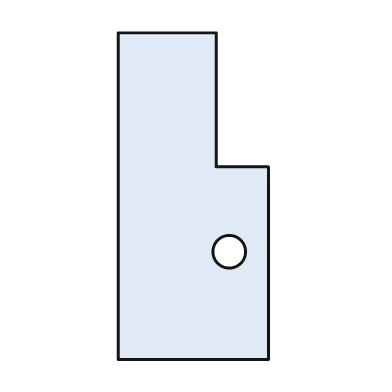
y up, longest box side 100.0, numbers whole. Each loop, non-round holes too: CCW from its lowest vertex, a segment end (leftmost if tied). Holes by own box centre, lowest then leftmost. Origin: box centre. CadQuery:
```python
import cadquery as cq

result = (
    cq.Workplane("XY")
    .moveTo(-23.0, -50.0)
    .lineTo(23.0, -50.0)
    .lineTo(23.0, 9.0)
    .lineTo(7.0, 9.0)
    .lineTo(7.0, 50.0)
    .lineTo(-23.0, 50.0)
    .close()
    .moveTo(11.0, -17.0)
    .circle(5.0)
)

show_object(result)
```